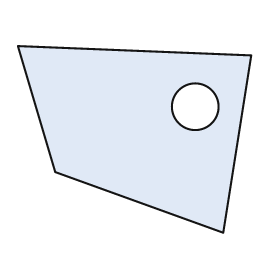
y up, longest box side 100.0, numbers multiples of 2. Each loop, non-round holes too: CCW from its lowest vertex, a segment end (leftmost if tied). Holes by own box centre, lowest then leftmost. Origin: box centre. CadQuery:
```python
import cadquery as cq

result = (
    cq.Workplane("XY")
    .moveTo(38.0, -40.0)
    .lineTo(50.0, 36.0)
    .lineTo(-50.0, 40.0)
    .lineTo(-34.0, -14.0)
    .close()
    .moveTo(26.0, 14.0)
    .circle(10.0)
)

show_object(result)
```